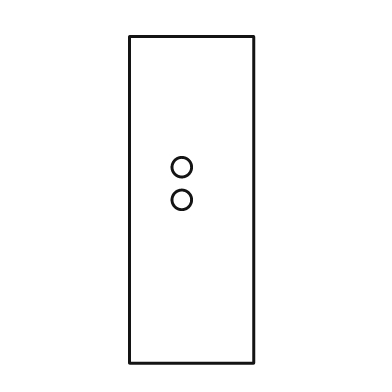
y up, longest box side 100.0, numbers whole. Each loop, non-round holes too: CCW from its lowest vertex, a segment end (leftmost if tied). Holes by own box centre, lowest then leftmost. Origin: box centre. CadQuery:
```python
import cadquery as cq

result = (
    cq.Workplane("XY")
    .moveTo(-19.0, -50.0)
    .lineTo(19.0, -50.0)
    .lineTo(19.0, 50.0)
    .lineTo(-19.0, 50.0)
    .close()
    .moveTo(-3.0, 0.0)
    .circle(3.0)
    .moveTo(-3.0, 10.0)
    .circle(3.0)
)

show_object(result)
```